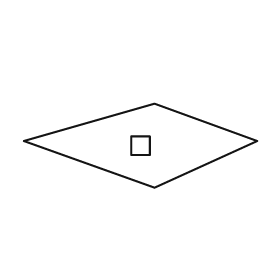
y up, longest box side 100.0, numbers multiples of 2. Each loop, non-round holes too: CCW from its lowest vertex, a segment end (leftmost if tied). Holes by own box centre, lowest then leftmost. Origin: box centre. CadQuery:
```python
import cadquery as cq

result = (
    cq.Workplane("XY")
    .moveTo(6.0, -18.0)
    .lineTo(50.0, 2.0)
    .lineTo(6.0, 18.0)
    .lineTo(-50.0, 2.0)
    .close()
    .moveTo(-4.0, -4.0)
    .lineTo(4.0, -4.0)
    .lineTo(4.0, 4.0)
    .lineTo(-4.0, 4.0)
    .close()
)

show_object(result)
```